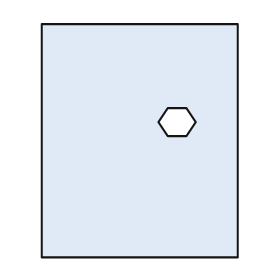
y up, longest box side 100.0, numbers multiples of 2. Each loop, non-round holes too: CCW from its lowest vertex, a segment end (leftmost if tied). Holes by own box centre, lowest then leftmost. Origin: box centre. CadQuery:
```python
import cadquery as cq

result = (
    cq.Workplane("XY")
    .moveTo(-42.0, -50.0)
    .lineTo(42.0, -50.0)
    .lineTo(42.0, 50.0)
    .lineTo(-42.0, 50.0)
    .close()
    .moveTo(12.0, 2.0)
    .lineTo(20.0, 2.0)
    .lineTo(24.0, 8.0)
    .lineTo(20.0, 14.0)
    .lineTo(12.0, 14.0)
    .lineTo(8.0, 8.0)
    .close()
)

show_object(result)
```